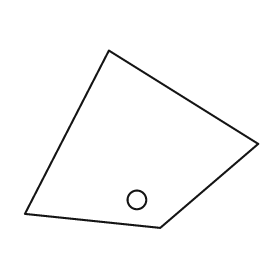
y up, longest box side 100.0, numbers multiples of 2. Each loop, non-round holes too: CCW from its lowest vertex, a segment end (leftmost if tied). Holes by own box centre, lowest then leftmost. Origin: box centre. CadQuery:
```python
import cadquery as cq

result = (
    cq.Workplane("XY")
    .moveTo(8.0, -38.0)
    .lineTo(50.0, -2.0)
    .lineTo(-14.0, 38.0)
    .lineTo(-50.0, -32.0)
    .close()
    .moveTo(-2.0, -26.0)
    .circle(4.0)
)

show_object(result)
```